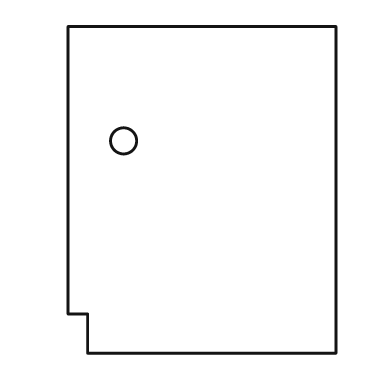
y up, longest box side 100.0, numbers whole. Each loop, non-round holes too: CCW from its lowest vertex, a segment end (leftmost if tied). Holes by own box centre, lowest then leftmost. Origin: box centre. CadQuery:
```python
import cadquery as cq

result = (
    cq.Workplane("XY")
    .moveTo(-35.0, -50.0)
    .lineTo(41.0, -50.0)
    .lineTo(41.0, 50.0)
    .lineTo(-41.0, 50.0)
    .lineTo(-41.0, -38.0)
    .lineTo(-35.0, -38.0)
    .close()
    .moveTo(-24.0, 15.0)
    .circle(4.0)
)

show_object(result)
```